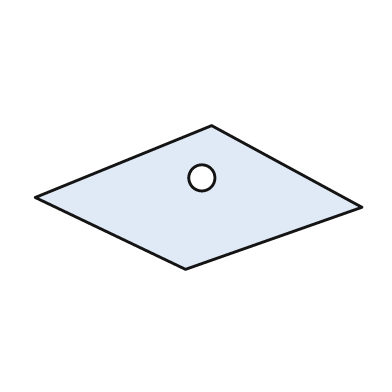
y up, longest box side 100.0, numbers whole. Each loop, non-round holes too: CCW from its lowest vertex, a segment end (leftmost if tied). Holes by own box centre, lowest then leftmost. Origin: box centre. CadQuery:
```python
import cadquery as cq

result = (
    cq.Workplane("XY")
    .moveTo(-4.0, -22.0)
    .lineTo(50.0, -3.0)
    .lineTo(4.0, 22.0)
    .lineTo(-50.0, 0.0)
    .close()
    .moveTo(1.0, 6.0)
    .circle(4.0)
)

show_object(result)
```